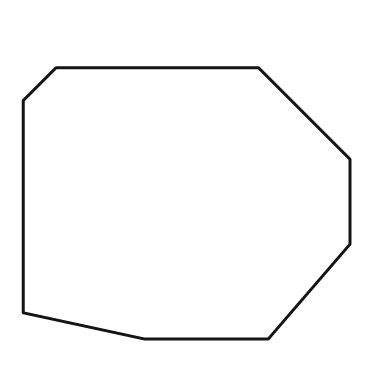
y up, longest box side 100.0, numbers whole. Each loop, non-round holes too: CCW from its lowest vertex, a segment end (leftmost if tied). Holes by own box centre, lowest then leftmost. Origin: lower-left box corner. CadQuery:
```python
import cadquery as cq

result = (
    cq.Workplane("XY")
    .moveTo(37.0, 0.0)
    .lineTo(75.0, 0.0)
    .lineTo(100.0, 29.0)
    .lineTo(100.0, 55.0)
    .lineTo(72.0, 83.0)
    .lineTo(10.0, 83.0)
    .lineTo(0.0, 73.0)
    .lineTo(0.0, 8.0)
    .close()
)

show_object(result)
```